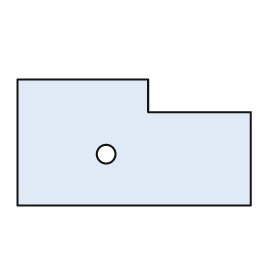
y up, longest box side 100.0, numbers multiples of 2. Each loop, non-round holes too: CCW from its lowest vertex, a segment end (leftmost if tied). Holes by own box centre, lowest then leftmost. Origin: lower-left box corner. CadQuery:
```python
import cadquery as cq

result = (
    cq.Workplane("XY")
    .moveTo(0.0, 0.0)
    .lineTo(100.0, 0.0)
    .lineTo(100.0, 40.0)
    .lineTo(56.0, 40.0)
    .lineTo(56.0, 54.0)
    .lineTo(0.0, 54.0)
    .close()
    .moveTo(38.0, 22.0)
    .circle(4.0)
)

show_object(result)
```